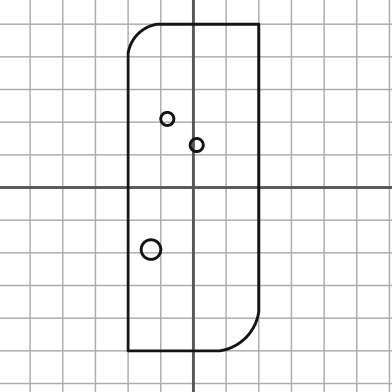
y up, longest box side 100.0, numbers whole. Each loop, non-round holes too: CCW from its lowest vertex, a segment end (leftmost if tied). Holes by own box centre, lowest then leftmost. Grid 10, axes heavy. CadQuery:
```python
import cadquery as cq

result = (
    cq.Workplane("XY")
    .moveTo(-20.0, -50.0)
    .lineTo(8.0, -50.0)
    .threePointArc((16.0, -46.0), (20.0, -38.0))
    .lineTo(20.0, 50.0)
    .lineTo(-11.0, 50.0)
    .threePointArc((-17.0, 47.0), (-20.0, 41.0))
    .close()
    .moveTo(-13.0, -19.0)
    .circle(3.0)
    .moveTo(1.0, 13.0)
    .circle(2.0)
    .moveTo(-8.0, 21.0)
    .circle(2.0)
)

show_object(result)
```